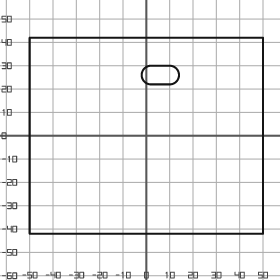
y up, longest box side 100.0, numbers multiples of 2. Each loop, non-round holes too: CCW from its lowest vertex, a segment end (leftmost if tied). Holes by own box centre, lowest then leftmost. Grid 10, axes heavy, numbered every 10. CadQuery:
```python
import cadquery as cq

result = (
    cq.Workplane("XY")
    .moveTo(-50.0, -42.0)
    .lineTo(50.0, -42.0)
    .lineTo(50.0, 42.0)
    .lineTo(-50.0, 42.0)
    .close()
    .moveTo(2.0, 22.0)
    .lineTo(10.0, 22.0)
    .threePointArc((14.0, 26.0), (10.0, 30.0))
    .lineTo(2.0, 30.0)
    .threePointArc((-2.0, 26.0), (2.0, 22.0))
    .close()
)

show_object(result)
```